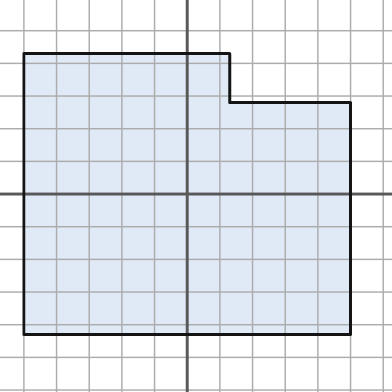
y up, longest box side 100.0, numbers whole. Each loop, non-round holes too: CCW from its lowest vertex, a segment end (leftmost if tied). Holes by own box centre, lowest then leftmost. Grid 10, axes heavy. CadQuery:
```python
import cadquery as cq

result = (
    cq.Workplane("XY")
    .moveTo(-50.0, -43.0)
    .lineTo(50.0, -43.0)
    .lineTo(50.0, 28.0)
    .lineTo(13.0, 28.0)
    .lineTo(13.0, 43.0)
    .lineTo(-50.0, 43.0)
    .close()
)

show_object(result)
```